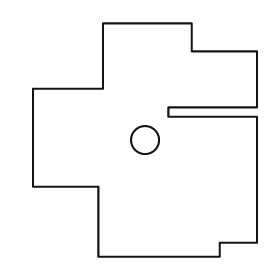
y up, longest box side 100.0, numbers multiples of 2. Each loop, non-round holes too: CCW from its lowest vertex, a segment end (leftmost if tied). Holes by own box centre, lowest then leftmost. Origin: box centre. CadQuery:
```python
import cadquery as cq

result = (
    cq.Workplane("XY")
    .moveTo(-20.0, -50.0)
    .lineTo(32.0, -50.0)
    .lineTo(32.0, -44.0)
    .lineTo(48.0, -44.0)
    .lineTo(48.0, 10.0)
    .lineTo(10.0, 10.0)
    .lineTo(10.0, 14.0)
    .lineTo(48.0, 14.0)
    .lineTo(48.0, 38.0)
    .lineTo(20.0, 38.0)
    .lineTo(20.0, 50.0)
    .lineTo(-18.0, 50.0)
    .lineTo(-18.0, 22.0)
    .lineTo(-48.0, 22.0)
    .lineTo(-48.0, -20.0)
    .lineTo(-20.0, -20.0)
    .close()
    .moveTo(0.0, 0.0)
    .circle(6.0)
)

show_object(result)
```